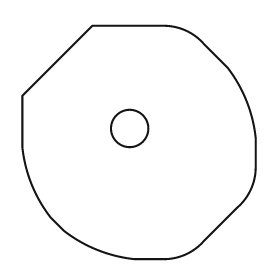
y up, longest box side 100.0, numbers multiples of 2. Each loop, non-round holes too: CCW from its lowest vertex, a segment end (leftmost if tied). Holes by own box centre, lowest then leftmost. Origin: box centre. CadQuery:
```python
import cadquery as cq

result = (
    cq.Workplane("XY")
    .moveTo(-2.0, -50.0)
    .lineTo(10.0, -50.0)
    .threePointArc((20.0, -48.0), (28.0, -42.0))
    .lineTo(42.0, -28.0)
    .threePointArc((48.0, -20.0), (50.0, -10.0))
    .lineTo(50.0, 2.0)
    .threePointArc((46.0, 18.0), (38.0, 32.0))
    .lineTo(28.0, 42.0)
    .threePointArc((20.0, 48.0), (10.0, 50.0))
    .lineTo(-20.0, 50.0)
    .lineTo(-50.0, 20.0)
    .lineTo(-50.0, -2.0)
    .threePointArc((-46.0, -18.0), (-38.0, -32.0))
    .lineTo(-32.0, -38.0)
    .threePointArc((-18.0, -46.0), (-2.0, -50.0))
    .close()
    .moveTo(-4.0, 6.0)
    .circle(8.0)
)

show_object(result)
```